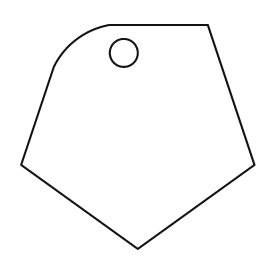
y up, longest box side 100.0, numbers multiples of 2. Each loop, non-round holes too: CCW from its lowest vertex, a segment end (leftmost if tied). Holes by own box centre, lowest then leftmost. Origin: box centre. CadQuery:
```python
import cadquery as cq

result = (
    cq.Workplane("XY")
    .moveTo(0.0, -48.0)
    .lineTo(50.0, -12.0)
    .lineTo(30.0, 48.0)
    .lineTo(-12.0, 48.0)
    .threePointArc((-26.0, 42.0), (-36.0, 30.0))
    .lineTo(-50.0, -12.0)
    .close()
    .moveTo(-6.0, 36.0)
    .circle(6.0)
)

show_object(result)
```